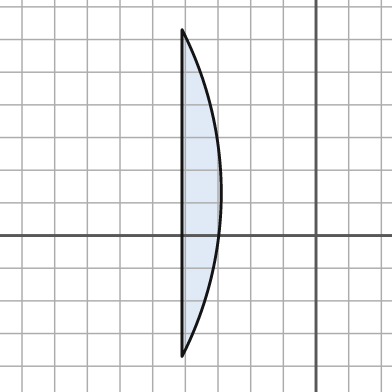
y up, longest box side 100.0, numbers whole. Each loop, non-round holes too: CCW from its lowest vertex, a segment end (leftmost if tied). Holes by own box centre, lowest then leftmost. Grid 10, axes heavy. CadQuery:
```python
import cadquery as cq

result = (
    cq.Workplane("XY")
    .moveTo(-41.0, -37.0)
    .threePointArc((-29.0, 13.0), (-41.0, 63.0))
    .close()
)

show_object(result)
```